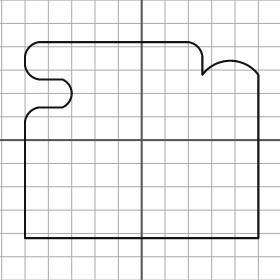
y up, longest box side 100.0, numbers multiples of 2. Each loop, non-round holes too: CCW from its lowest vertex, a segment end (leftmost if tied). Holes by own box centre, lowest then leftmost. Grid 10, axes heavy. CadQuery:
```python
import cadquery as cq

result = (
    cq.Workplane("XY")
    .moveTo(-50.0, -42.0)
    .lineTo(50.0, -42.0)
    .lineTo(50.0, 28.0)
    .threePointArc((38.0, 34.0), (26.0, 28.0))
    .lineTo(26.0, 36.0)
    .threePointArc((24.0, 40.0), (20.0, 42.0))
    .lineTo(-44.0, 42.0)
    .threePointArc((-48.0, 40.0), (-50.0, 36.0))
    .lineTo(-50.0, 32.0)
    .threePointArc((-48.0, 28.0), (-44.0, 26.0))
    .lineTo(-34.0, 26.0)
    .threePointArc((-30.0, 20.0), (-34.0, 14.0))
    .lineTo(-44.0, 14.0)
    .threePointArc((-48.0, 12.0), (-50.0, 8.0))
    .close()
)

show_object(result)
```